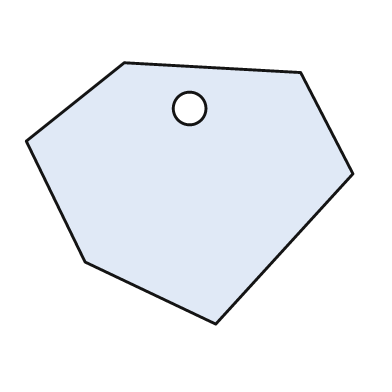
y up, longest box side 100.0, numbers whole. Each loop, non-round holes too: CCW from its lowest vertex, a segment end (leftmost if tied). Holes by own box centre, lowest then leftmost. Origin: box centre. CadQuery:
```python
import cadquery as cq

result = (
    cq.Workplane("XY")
    .moveTo(8.0, -40.0)
    .lineTo(50.0, 6.0)
    .lineTo(34.0, 37.0)
    .lineTo(-20.0, 40.0)
    .lineTo(-50.0, 16.0)
    .lineTo(-32.0, -21.0)
    .close()
    .moveTo(0.0, 26.0)
    .circle(5.0)
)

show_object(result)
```